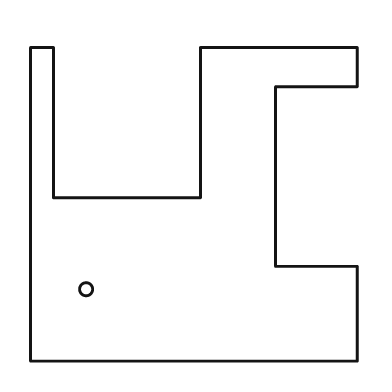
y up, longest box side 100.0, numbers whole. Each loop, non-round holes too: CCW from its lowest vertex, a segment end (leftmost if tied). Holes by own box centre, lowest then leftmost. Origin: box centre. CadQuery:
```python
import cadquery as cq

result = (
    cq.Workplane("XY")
    .moveTo(-50.0, -48.0)
    .lineTo(50.0, -48.0)
    .lineTo(50.0, -19.0)
    .lineTo(25.0, -19.0)
    .lineTo(25.0, 36.0)
    .lineTo(50.0, 36.0)
    .lineTo(50.0, 48.0)
    .lineTo(2.0, 48.0)
    .lineTo(2.0, 2.0)
    .lineTo(-43.0, 2.0)
    .lineTo(-43.0, 48.0)
    .lineTo(-50.0, 48.0)
    .close()
    .moveTo(-33.0, -26.0)
    .circle(2.0)
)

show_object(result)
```